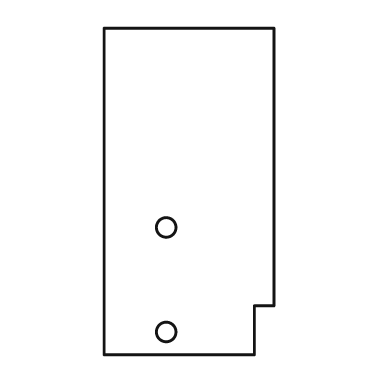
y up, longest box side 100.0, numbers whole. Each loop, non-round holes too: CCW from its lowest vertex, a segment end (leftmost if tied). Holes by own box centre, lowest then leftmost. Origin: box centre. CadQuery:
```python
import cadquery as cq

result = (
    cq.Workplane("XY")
    .moveTo(-26.0, -50.0)
    .lineTo(20.0, -50.0)
    .lineTo(20.0, -35.0)
    .lineTo(26.0, -35.0)
    .lineTo(26.0, 50.0)
    .lineTo(-26.0, 50.0)
    .close()
    .moveTo(-7.0, -43.0)
    .circle(3.0)
    .moveTo(-7.0, -11.0)
    .circle(3.0)
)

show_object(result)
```